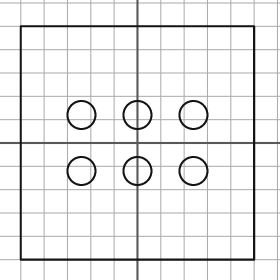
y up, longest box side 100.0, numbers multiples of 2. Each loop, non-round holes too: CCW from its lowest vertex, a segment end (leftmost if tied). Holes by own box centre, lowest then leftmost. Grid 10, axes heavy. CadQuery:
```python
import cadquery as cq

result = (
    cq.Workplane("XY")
    .moveTo(-50.0, -50.0)
    .lineTo(50.0, -50.0)
    .lineTo(50.0, 50.0)
    .lineTo(-50.0, 50.0)
    .close()
    .moveTo(-24.0, -12.0)
    .circle(6.0)
    .moveTo(0.0, -12.0)
    .circle(6.0)
    .moveTo(24.0, -12.0)
    .circle(6.0)
    .moveTo(-24.0, 12.0)
    .circle(6.0)
    .moveTo(0.0, 12.0)
    .circle(6.0)
    .moveTo(24.0, 12.0)
    .circle(6.0)
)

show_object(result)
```